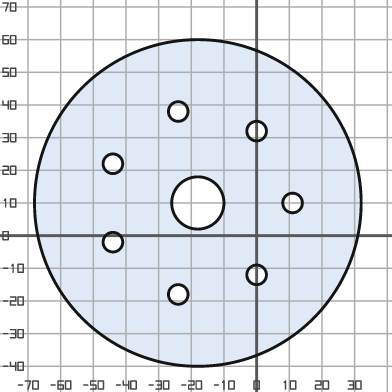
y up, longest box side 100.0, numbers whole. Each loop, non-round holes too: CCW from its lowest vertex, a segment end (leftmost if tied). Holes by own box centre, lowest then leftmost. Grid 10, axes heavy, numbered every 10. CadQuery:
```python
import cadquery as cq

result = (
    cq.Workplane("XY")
    .moveTo(-18.0, 10.0)
    .circle(50.0)
    .moveTo(-24.0, -18.0)
    .circle(3.0)
    .moveTo(0.0, -12.0)
    .circle(3.0)
    .moveTo(-44.0, -2.0)
    .circle(3.0)
    .moveTo(-18.0, 10.0)
    .circle(8.0)
    .moveTo(11.0, 10.0)
    .circle(3.0)
    .moveTo(-44.0, 22.0)
    .circle(3.0)
    .moveTo(0.0, 32.0)
    .circle(3.0)
    .moveTo(-24.0, 38.0)
    .circle(3.0)
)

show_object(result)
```